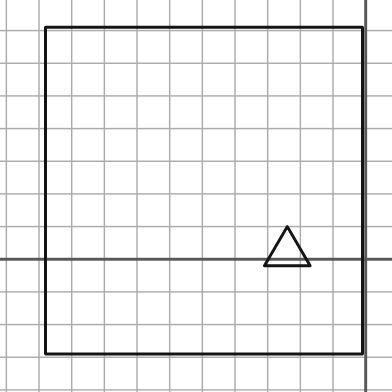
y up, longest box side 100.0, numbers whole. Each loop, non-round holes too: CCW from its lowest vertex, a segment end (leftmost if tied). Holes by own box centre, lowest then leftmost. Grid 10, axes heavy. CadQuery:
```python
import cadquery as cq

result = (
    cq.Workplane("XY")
    .moveTo(-98.0, -29.0)
    .lineTo(-1.0, -29.0)
    .lineTo(-1.0, 71.0)
    .lineTo(-98.0, 71.0)
    .close()
    .moveTo(-31.0, -2.0)
    .lineTo(-17.0, -2.0)
    .lineTo(-24.0, 10.0)
    .close()
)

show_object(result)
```